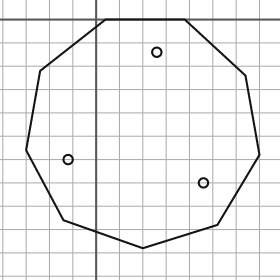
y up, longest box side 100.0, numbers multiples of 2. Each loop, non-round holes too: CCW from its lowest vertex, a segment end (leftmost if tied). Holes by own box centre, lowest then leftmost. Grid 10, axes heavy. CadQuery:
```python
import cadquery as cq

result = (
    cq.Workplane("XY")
    .moveTo(20.0, -98.0)
    .lineTo(52.0, -88.0)
    .lineTo(70.0, -58.0)
    .lineTo(64.0, -24.0)
    .lineTo(38.0, 0.0)
    .lineTo(4.0, 0.0)
    .lineTo(-24.0, -22.0)
    .lineTo(-30.0, -56.0)
    .lineTo(-14.0, -86.0)
    .close()
    .moveTo(46.0, -70.0)
    .circle(2.0)
    .moveTo(-12.0, -60.0)
    .circle(2.0)
    .moveTo(26.0, -14.0)
    .circle(2.0)
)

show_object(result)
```